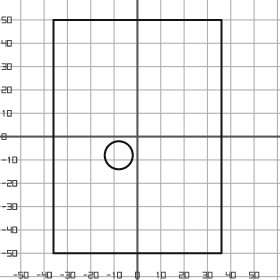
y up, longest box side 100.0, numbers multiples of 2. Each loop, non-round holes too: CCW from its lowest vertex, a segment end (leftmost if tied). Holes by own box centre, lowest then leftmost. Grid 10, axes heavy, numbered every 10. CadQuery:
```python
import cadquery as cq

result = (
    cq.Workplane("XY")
    .moveTo(-36.0, -50.0)
    .lineTo(36.0, -50.0)
    .lineTo(36.0, 50.0)
    .lineTo(-36.0, 50.0)
    .close()
    .moveTo(-8.0, -8.0)
    .circle(6.0)
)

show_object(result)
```